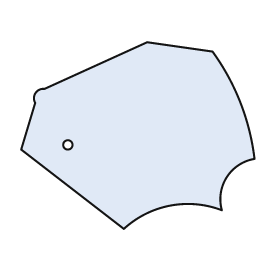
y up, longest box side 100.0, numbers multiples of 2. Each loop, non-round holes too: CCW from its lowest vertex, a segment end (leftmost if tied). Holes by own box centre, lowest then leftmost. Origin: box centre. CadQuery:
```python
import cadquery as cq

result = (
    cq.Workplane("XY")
    .moveTo(-6.0, -40.0)
    .threePointArc((14.0, -30.0), (36.0, -32.0))
    .threePointArc((38.0, -18.0), (50.0, -10.0))
    .threePointArc((44.0, 14.0), (32.0, 36.0))
    .lineTo(4.0, 40.0)
    .lineTo(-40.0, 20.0)
    .threePointArc((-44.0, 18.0), (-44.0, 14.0))
    .lineTo(-50.0, -6.0)
    .close()
    .moveTo(-30.0, -4.0)
    .circle(2.0)
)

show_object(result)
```